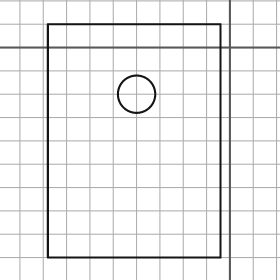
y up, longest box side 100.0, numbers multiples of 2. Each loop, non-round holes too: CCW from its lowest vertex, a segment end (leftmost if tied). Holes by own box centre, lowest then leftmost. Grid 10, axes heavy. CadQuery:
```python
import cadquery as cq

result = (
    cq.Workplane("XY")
    .moveTo(-78.0, -90.0)
    .lineTo(-4.0, -90.0)
    .lineTo(-4.0, 10.0)
    .lineTo(-78.0, 10.0)
    .close()
    .moveTo(-40.0, -20.0)
    .circle(8.0)
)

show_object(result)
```